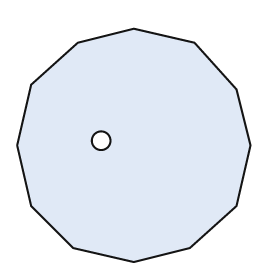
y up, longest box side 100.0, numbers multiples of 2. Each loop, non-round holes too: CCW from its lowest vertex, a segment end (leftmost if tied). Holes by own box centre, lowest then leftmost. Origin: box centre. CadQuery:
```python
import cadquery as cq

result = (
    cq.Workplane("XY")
    .moveTo(0.0, -50.0)
    .lineTo(24.0, -44.0)
    .lineTo(44.0, -26.0)
    .lineTo(50.0, 0.0)
    .lineTo(44.0, 24.0)
    .lineTo(26.0, 44.0)
    .lineTo(0.0, 50.0)
    .lineTo(-24.0, 44.0)
    .lineTo(-44.0, 26.0)
    .lineTo(-50.0, 0.0)
    .lineTo(-44.0, -26.0)
    .lineTo(-26.0, -44.0)
    .close()
    .moveTo(-14.0, 2.0)
    .circle(4.0)
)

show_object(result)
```